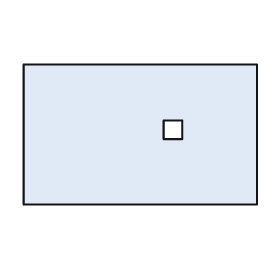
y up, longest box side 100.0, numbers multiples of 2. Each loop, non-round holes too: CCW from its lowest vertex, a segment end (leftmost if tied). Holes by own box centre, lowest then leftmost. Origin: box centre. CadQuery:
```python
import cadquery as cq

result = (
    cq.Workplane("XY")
    .moveTo(-50.0, -30.0)
    .lineTo(50.0, -30.0)
    .lineTo(50.0, 30.0)
    .lineTo(-50.0, 30.0)
    .close()
    .moveTo(10.0, -2.0)
    .lineTo(18.0, -2.0)
    .lineTo(18.0, 6.0)
    .lineTo(10.0, 6.0)
    .close()
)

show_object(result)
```